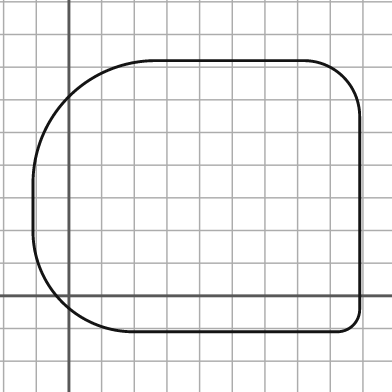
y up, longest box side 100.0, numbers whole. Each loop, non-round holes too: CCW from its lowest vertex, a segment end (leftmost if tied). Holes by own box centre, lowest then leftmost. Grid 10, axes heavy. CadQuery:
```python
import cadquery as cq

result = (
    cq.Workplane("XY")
    .moveTo(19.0, -11.0)
    .lineTo(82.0, -11.0)
    .threePointArc((87.0, -9.0), (89.0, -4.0))
    .lineTo(89.0, 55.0)
    .threePointArc((84.0, 67.0), (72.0, 72.0))
    .lineTo(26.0, 72.0)
    .threePointArc((0.0, 61.0), (-11.0, 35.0))
    .lineTo(-11.0, 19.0)
    .threePointArc((-2.0, -2.0), (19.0, -11.0))
    .close()
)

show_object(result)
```